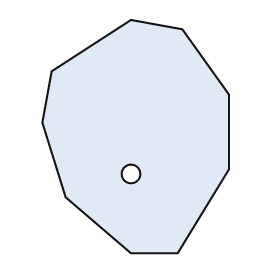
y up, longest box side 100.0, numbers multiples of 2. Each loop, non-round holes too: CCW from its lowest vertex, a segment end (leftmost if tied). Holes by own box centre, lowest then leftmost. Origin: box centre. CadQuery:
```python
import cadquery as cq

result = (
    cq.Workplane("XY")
    .moveTo(-2.0, -50.0)
    .lineTo(18.0, -50.0)
    .lineTo(40.0, -14.0)
    .lineTo(40.0, 18.0)
    .lineTo(20.0, 46.0)
    .lineTo(-2.0, 50.0)
    .lineTo(-36.0, 28.0)
    .lineTo(-40.0, 6.0)
    .lineTo(-30.0, -26.0)
    .close()
    .moveTo(-2.0, -16.0)
    .circle(4.0)
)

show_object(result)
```